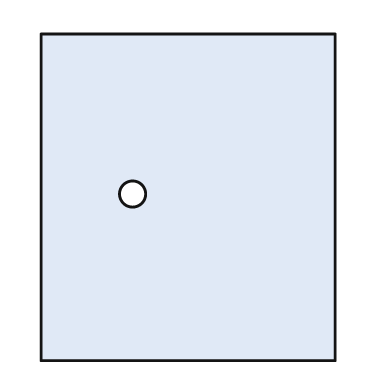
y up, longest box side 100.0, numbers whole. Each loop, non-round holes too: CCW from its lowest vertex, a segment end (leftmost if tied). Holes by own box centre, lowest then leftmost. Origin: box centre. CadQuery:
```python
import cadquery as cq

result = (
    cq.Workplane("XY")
    .moveTo(-45.0, -50.0)
    .lineTo(45.0, -50.0)
    .lineTo(45.0, 50.0)
    .lineTo(-45.0, 50.0)
    .close()
    .moveTo(-17.0, 1.0)
    .circle(4.0)
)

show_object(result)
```